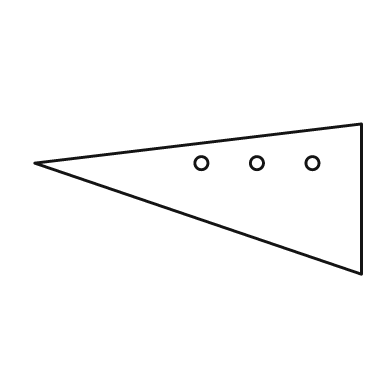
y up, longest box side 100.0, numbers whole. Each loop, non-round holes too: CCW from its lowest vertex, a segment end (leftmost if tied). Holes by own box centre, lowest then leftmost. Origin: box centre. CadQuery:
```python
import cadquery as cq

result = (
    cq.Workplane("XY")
    .moveTo(50.0, -23.0)
    .lineTo(50.0, 23.0)
    .lineTo(-50.0, 11.0)
    .close()
    .moveTo(1.0, 11.0)
    .circle(2.0)
    .moveTo(18.0, 11.0)
    .circle(2.0)
    .moveTo(35.0, 11.0)
    .circle(2.0)
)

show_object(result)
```